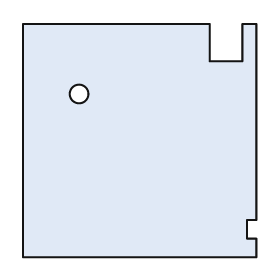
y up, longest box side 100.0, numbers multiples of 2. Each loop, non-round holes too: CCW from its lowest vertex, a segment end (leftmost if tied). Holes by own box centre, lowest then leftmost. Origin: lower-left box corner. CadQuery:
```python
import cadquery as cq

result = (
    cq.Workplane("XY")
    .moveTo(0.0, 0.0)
    .lineTo(100.0, 0.0)
    .lineTo(100.0, 8.0)
    .lineTo(96.0, 8.0)
    .lineTo(96.0, 16.0)
    .lineTo(100.0, 16.0)
    .lineTo(100.0, 100.0)
    .lineTo(94.0, 100.0)
    .lineTo(94.0, 84.0)
    .lineTo(80.0, 84.0)
    .lineTo(80.0, 100.0)
    .lineTo(0.0, 100.0)
    .close()
    .moveTo(24.0, 70.0)
    .circle(4.0)
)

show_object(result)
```